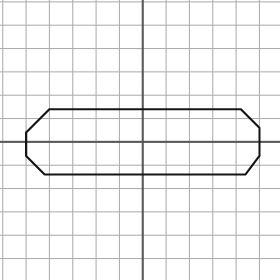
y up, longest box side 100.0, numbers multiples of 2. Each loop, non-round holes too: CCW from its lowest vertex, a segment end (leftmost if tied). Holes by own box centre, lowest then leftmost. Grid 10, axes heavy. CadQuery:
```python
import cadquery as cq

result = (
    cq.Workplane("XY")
    .moveTo(-42.0, -14.0)
    .lineTo(44.0, -14.0)
    .lineTo(50.0, -6.0)
    .lineTo(50.0, 6.0)
    .lineTo(42.0, 14.0)
    .lineTo(-40.0, 14.0)
    .lineTo(-50.0, 4.0)
    .lineTo(-50.0, -6.0)
    .close()
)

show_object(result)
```